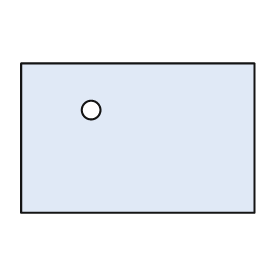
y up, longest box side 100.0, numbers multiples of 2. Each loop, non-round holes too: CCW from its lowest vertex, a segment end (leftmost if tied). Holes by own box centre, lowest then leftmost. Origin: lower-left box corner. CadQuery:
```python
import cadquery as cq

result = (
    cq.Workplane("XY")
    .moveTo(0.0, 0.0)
    .lineTo(100.0, 0.0)
    .lineTo(100.0, 64.0)
    .lineTo(0.0, 64.0)
    .close()
    .moveTo(30.0, 44.0)
    .circle(4.0)
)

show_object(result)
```